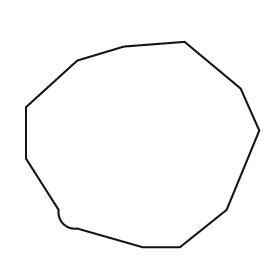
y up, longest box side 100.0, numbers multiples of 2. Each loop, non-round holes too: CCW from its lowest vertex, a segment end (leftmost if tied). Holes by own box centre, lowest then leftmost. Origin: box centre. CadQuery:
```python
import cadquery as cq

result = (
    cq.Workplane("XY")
    .moveTo(0.0, -44.0)
    .lineTo(16.0, -44.0)
    .lineTo(36.0, -28.0)
    .lineTo(50.0, 6.0)
    .lineTo(42.0, 24.0)
    .lineTo(18.0, 44.0)
    .lineTo(-8.0, 42.0)
    .lineTo(-28.0, 36.0)
    .lineTo(-50.0, 16.0)
    .lineTo(-50.0, -6.0)
    .lineTo(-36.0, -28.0)
    .threePointArc((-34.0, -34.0), (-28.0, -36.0))
    .close()
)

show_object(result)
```